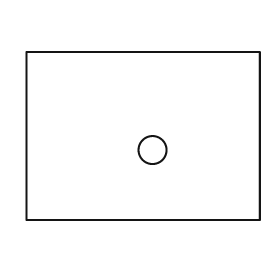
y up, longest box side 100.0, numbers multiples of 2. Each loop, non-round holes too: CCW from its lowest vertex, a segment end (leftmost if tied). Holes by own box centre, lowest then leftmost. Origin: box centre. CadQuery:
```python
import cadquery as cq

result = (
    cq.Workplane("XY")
    .moveTo(-50.0, -36.0)
    .lineTo(50.0, -36.0)
    .lineTo(50.0, 36.0)
    .lineTo(-50.0, 36.0)
    .close()
    .moveTo(4.0, -6.0)
    .circle(6.0)
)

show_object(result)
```